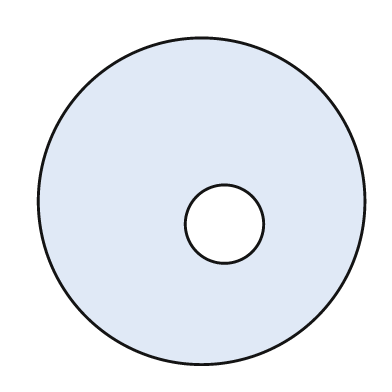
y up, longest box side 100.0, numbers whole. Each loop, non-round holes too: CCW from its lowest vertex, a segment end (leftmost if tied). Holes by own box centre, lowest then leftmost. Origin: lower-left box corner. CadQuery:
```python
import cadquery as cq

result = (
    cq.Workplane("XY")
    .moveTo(50.0, 50.0)
    .circle(50.0)
    .moveTo(57.0, 43.0)
    .circle(12.0)
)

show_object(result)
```